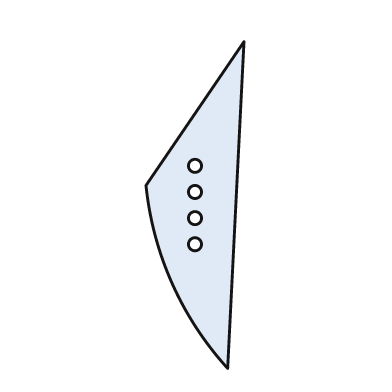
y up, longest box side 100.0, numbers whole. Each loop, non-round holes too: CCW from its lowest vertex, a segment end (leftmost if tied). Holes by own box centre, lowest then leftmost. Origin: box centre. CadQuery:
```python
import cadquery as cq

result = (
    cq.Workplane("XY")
    .moveTo(10.0, -50.0)
    .lineTo(15.0, 50.0)
    .lineTo(-15.0, 6.0)
    .threePointArc((-7.0, -24.0), (10.0, -50.0))
    .close()
    .moveTo(0.0, -12.0)
    .circle(2.0)
    .moveTo(0.0, -4.0)
    .circle(2.0)
    .moveTo(0.0, 4.0)
    .circle(2.0)
    .moveTo(0.0, 12.0)
    .circle(2.0)
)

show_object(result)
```